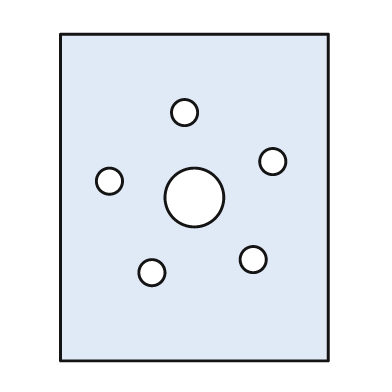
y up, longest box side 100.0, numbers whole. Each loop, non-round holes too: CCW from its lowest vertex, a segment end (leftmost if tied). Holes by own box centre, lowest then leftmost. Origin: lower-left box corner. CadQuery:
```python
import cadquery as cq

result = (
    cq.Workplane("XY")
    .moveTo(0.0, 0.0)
    .lineTo(82.0, 0.0)
    .lineTo(82.0, 100.0)
    .lineTo(0.0, 100.0)
    .close()
    .moveTo(28.0, 27.0)
    .circle(4.0)
    .moveTo(59.0, 31.0)
    .circle(4.0)
    .moveTo(41.0, 50.0)
    .circle(9.0)
    .moveTo(15.0, 55.0)
    .circle(4.0)
    .moveTo(65.0, 61.0)
    .circle(4.0)
    .moveTo(38.0, 76.0)
    .circle(4.0)
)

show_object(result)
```